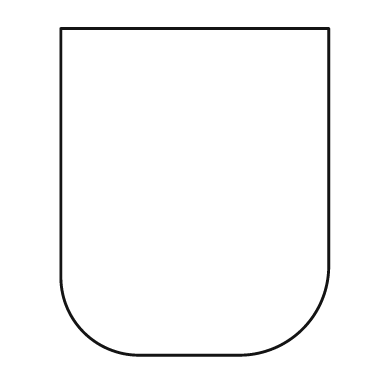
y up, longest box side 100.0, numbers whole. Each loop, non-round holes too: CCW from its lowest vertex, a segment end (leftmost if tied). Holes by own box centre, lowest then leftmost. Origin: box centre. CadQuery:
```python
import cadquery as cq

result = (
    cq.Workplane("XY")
    .moveTo(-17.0, -50.0)
    .lineTo(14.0, -50.0)
    .threePointArc((33.0, -42.0), (41.0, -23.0))
    .lineTo(41.0, 50.0)
    .lineTo(-41.0, 50.0)
    .lineTo(-41.0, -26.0)
    .threePointArc((-34.0, -43.0), (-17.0, -50.0))
    .close()
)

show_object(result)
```